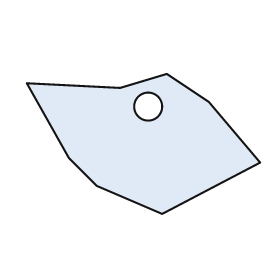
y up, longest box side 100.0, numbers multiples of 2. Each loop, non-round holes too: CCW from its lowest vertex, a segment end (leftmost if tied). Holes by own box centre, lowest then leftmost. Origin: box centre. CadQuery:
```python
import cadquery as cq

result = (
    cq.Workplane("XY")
    .moveTo(8.0, -30.0)
    .lineTo(50.0, -8.0)
    .lineTo(28.0, 18.0)
    .lineTo(10.0, 30.0)
    .lineTo(-10.0, 24.0)
    .lineTo(-50.0, 26.0)
    .lineTo(-32.0, -6.0)
    .lineTo(-20.0, -18.0)
    .close()
    .moveTo(2.0, 16.0)
    .circle(6.0)
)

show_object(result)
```